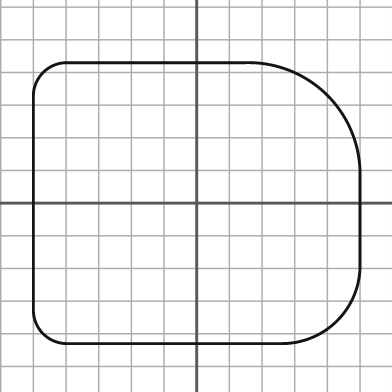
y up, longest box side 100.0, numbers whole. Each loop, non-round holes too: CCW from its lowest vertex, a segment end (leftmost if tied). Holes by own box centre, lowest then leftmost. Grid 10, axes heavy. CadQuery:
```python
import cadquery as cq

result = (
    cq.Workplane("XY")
    .moveTo(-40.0, -43.0)
    .lineTo(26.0, -43.0)
    .threePointArc((43.0, -36.0), (50.0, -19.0))
    .lineTo(50.0, 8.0)
    .threePointArc((40.0, 33.0), (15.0, 43.0))
    .lineTo(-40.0, 43.0)
    .threePointArc((-47.0, 40.0), (-50.0, 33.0))
    .lineTo(-50.0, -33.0)
    .threePointArc((-47.0, -40.0), (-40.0, -43.0))
    .close()
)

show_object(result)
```